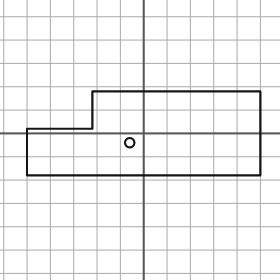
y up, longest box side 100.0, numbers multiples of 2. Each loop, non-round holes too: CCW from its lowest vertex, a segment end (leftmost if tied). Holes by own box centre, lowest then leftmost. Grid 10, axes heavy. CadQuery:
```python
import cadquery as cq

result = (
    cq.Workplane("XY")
    .moveTo(-50.0, -18.0)
    .lineTo(50.0, -18.0)
    .lineTo(50.0, 18.0)
    .lineTo(-22.0, 18.0)
    .lineTo(-22.0, 2.0)
    .lineTo(-50.0, 2.0)
    .close()
    .moveTo(-6.0, -4.0)
    .circle(2.0)
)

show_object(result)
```